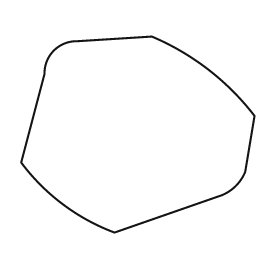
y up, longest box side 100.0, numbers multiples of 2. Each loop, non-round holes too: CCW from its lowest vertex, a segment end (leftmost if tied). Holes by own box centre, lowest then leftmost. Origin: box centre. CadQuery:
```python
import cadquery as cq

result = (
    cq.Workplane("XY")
    .moveTo(-10.0, -42.0)
    .lineTo(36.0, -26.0)
    .threePointArc((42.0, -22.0), (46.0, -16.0))
    .lineTo(50.0, 8.0)
    .threePointArc((30.0, 28.0), (6.0, 42.0))
    .lineTo(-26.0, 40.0)
    .threePointArc((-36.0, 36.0), (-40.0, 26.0))
    .lineTo(-50.0, -12.0)
    .threePointArc((-32.0, -30.0), (-10.0, -42.0))
    .close()
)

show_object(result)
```